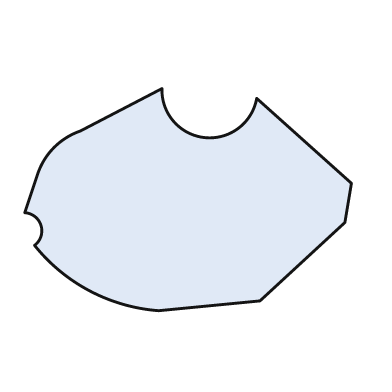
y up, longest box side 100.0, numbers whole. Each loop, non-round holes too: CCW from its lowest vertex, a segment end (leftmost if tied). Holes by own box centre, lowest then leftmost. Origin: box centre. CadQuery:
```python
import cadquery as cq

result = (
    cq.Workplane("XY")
    .moveTo(-9.0, -34.0)
    .lineTo(22.0, -31.0)
    .lineTo(48.0, -7.0)
    .lineTo(50.0, 5.0)
    .lineTo(21.0, 31.0)
    .threePointArc((5.0, 19.0), (-8.0, 34.0))
    .lineTo(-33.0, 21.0)
    .threePointArc((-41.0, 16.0), (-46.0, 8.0))
    .lineTo(-50.0, -4.0)
    .threePointArc((-45.0, -8.0), (-47.0, -14.0))
    .threePointArc((-30.0, -28.0), (-9.0, -34.0))
    .close()
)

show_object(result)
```